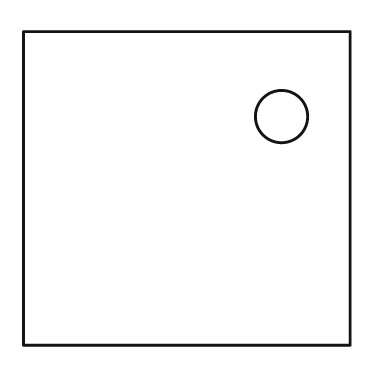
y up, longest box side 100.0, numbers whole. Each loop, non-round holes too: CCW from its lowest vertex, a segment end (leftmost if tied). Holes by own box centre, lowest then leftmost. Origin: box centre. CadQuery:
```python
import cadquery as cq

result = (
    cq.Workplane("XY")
    .moveTo(-50.0, -48.0)
    .lineTo(50.0, -48.0)
    .lineTo(50.0, 48.0)
    .lineTo(-50.0, 48.0)
    .close()
    .moveTo(29.0, 22.0)
    .circle(8.0)
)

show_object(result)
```